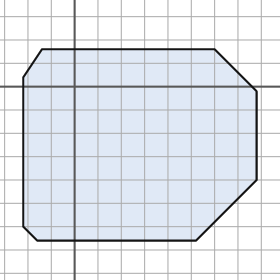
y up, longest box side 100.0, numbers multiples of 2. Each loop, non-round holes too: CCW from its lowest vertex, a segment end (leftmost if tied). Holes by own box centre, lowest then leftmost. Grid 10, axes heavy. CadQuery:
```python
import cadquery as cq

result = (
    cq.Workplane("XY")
    .moveTo(-16.0, -66.0)
    .lineTo(52.0, -66.0)
    .lineTo(78.0, -40.0)
    .lineTo(78.0, -2.0)
    .lineTo(60.0, 16.0)
    .lineTo(-14.0, 16.0)
    .lineTo(-22.0, 4.0)
    .lineTo(-22.0, -60.0)
    .close()
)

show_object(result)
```